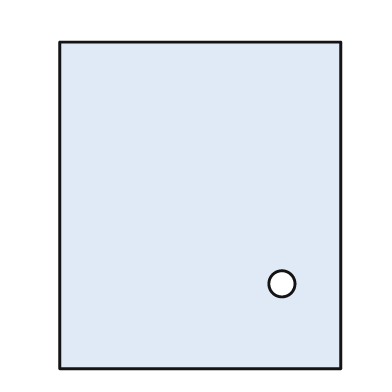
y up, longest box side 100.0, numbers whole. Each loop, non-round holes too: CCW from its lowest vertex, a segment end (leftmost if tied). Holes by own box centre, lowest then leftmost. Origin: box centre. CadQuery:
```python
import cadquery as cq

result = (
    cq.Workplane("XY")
    .moveTo(-43.0, -50.0)
    .lineTo(43.0, -50.0)
    .lineTo(43.0, 50.0)
    .lineTo(-43.0, 50.0)
    .close()
    .moveTo(25.0, -24.0)
    .circle(4.0)
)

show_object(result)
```